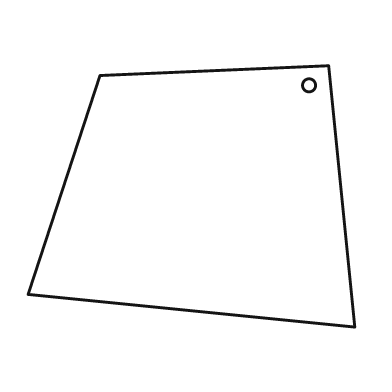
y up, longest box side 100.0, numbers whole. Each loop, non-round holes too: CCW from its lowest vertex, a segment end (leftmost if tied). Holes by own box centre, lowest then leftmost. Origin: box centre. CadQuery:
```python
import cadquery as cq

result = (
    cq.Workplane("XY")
    .moveTo(50.0, -40.0)
    .lineTo(42.0, 40.0)
    .lineTo(-28.0, 37.0)
    .lineTo(-50.0, -30.0)
    .close()
    .moveTo(36.0, 34.0)
    .circle(2.0)
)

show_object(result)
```